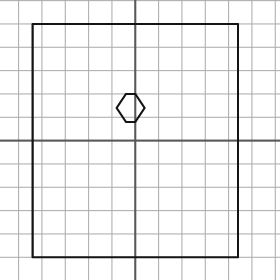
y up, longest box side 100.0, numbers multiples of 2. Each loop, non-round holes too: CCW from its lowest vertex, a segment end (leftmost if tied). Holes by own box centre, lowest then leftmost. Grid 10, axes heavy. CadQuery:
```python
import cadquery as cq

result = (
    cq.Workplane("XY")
    .moveTo(-44.0, -50.0)
    .lineTo(44.0, -50.0)
    .lineTo(44.0, 50.0)
    .lineTo(-44.0, 50.0)
    .close()
    .moveTo(-4.0, 8.0)
    .lineTo(0.0, 8.0)
    .lineTo(4.0, 14.0)
    .lineTo(0.0, 20.0)
    .lineTo(-4.0, 20.0)
    .lineTo(-8.0, 14.0)
    .close()
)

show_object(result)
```